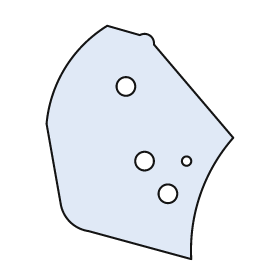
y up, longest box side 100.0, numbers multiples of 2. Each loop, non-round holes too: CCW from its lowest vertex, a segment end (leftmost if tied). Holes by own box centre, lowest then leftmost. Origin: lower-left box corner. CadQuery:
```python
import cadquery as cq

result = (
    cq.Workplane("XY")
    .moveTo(62.0, 0.0)
    .threePointArc((66.0, 28.0), (80.0, 52.0))
    .lineTo(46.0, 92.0)
    .threePointArc((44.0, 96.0), (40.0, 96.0))
    .lineTo(26.0, 100.0)
    .threePointArc((8.0, 82.0), (0.0, 58.0))
    .lineTo(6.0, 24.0)
    .threePointArc((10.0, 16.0), (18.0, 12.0))
    .close()
    .moveTo(52.0, 28.0)
    .circle(4.0)
    .moveTo(42.0, 42.0)
    .circle(4.0)
    .moveTo(60.0, 42.0)
    .circle(2.0)
    .moveTo(34.0, 74.0)
    .circle(4.0)
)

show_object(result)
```